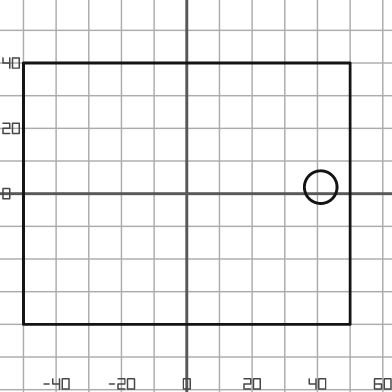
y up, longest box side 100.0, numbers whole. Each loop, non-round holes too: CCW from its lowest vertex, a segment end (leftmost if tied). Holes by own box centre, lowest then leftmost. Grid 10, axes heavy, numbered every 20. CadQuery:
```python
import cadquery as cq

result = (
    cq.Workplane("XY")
    .moveTo(-50.0, -40.0)
    .lineTo(50.0, -40.0)
    .lineTo(50.0, 40.0)
    .lineTo(-50.0, 40.0)
    .close()
    .moveTo(41.0, 2.0)
    .circle(5.0)
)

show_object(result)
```